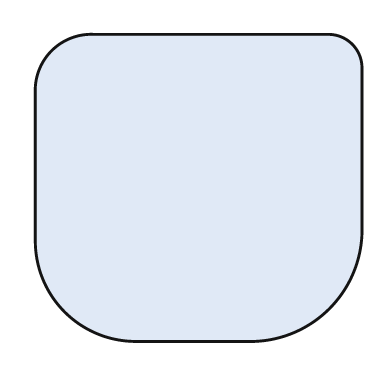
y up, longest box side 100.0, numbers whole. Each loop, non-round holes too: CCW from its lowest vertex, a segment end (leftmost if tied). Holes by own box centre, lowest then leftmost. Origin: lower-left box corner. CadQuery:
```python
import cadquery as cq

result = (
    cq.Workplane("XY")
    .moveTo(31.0, 0.0)
    .lineTo(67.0, 0.0)
    .threePointArc((90.0, 10.0), (100.0, 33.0))
    .lineTo(100.0, 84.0)
    .threePointArc((97.0, 91.0), (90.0, 94.0))
    .lineTo(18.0, 94.0)
    .threePointArc((5.0, 89.0), (0.0, 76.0))
    .lineTo(0.0, 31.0)
    .threePointArc((9.0, 9.0), (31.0, 0.0))
    .close()
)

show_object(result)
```